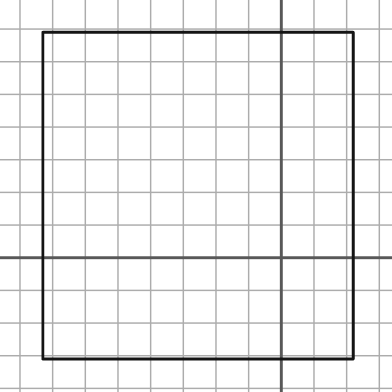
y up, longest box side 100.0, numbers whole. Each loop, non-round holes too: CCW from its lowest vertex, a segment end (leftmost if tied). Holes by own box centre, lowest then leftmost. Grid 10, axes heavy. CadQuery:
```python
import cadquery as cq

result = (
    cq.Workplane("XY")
    .moveTo(-73.0, -31.0)
    .lineTo(22.0, -31.0)
    .lineTo(22.0, 69.0)
    .lineTo(-73.0, 69.0)
    .close()
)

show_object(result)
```